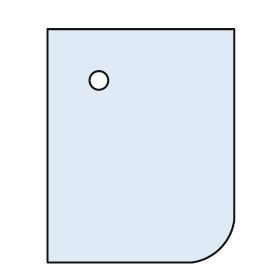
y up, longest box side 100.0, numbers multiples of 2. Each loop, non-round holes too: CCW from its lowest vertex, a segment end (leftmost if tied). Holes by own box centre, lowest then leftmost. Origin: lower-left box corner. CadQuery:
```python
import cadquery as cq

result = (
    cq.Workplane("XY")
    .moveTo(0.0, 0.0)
    .lineTo(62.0, 0.0)
    .threePointArc((74.0, 6.0), (80.0, 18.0))
    .lineTo(80.0, 100.0)
    .lineTo(0.0, 100.0)
    .close()
    .moveTo(22.0, 78.0)
    .circle(4.0)
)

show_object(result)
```